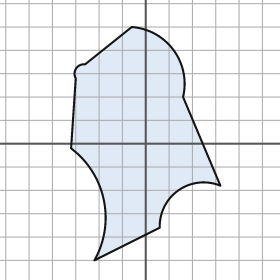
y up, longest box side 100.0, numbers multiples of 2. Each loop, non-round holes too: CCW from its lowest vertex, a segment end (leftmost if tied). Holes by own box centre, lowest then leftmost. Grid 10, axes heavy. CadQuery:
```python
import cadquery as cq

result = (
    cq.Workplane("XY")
    .moveTo(-22.0, -50.0)
    .lineTo(6.0, -36.0)
    .threePointArc((14.0, -20.0), (32.0, -18.0))
    .lineTo(16.0, 20.0)
    .threePointArc((12.0, 40.0), (-6.0, 50.0))
    .lineTo(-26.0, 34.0)
    .threePointArc((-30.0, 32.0), (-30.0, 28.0))
    .lineTo(-32.0, -2.0)
    .threePointArc((-18.0, -24.0), (-22.0, -50.0))
    .close()
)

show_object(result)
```